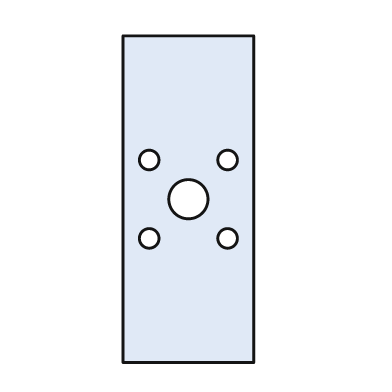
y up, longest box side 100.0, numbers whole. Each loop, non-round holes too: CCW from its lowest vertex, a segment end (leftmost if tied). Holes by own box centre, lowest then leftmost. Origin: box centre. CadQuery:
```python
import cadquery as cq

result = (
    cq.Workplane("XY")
    .moveTo(-20.0, -50.0)
    .lineTo(20.0, -50.0)
    .lineTo(20.0, 50.0)
    .lineTo(-20.0, 50.0)
    .close()
    .moveTo(-12.0, -12.0)
    .circle(3.0)
    .moveTo(12.0, -12.0)
    .circle(3.0)
    .moveTo(0.0, 0.0)
    .circle(6.0)
    .moveTo(-12.0, 12.0)
    .circle(3.0)
    .moveTo(12.0, 12.0)
    .circle(3.0)
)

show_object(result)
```